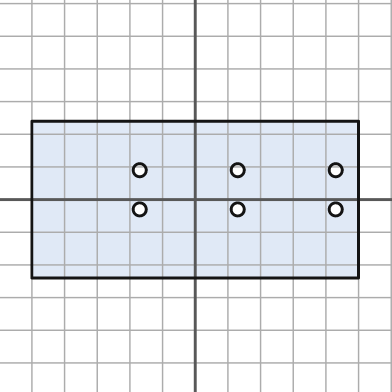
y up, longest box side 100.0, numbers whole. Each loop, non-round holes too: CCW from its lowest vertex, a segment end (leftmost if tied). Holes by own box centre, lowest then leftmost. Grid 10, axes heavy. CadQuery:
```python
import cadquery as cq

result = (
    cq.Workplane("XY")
    .moveTo(-50.0, -24.0)
    .lineTo(50.0, -24.0)
    .lineTo(50.0, 24.0)
    .lineTo(-50.0, 24.0)
    .close()
    .moveTo(-17.0, -3.0)
    .circle(2.0)
    .moveTo(13.0, -3.0)
    .circle(2.0)
    .moveTo(43.0, -3.0)
    .circle(2.0)
    .moveTo(-17.0, 9.0)
    .circle(2.0)
    .moveTo(13.0, 9.0)
    .circle(2.0)
    .moveTo(43.0, 9.0)
    .circle(2.0)
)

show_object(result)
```